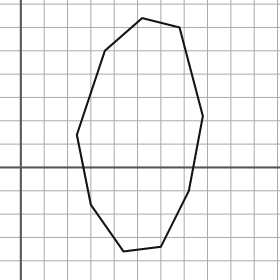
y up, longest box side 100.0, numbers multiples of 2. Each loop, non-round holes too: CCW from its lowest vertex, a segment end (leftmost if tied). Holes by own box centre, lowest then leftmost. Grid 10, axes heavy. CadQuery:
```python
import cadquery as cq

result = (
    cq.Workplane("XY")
    .moveTo(44.0, -36.0)
    .lineTo(60.0, -34.0)
    .lineTo(72.0, -10.0)
    .lineTo(78.0, 22.0)
    .lineTo(68.0, 60.0)
    .lineTo(52.0, 64.0)
    .lineTo(36.0, 50.0)
    .lineTo(24.0, 14.0)
    .lineTo(30.0, -16.0)
    .close()
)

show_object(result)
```